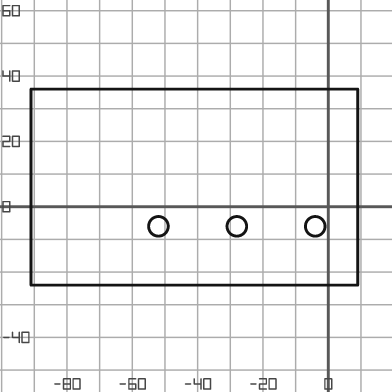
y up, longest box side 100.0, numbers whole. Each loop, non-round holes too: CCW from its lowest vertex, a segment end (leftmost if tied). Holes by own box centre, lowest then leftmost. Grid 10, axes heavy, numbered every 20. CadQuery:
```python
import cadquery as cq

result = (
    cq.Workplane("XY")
    .moveTo(-91.0, -24.0)
    .lineTo(9.0, -24.0)
    .lineTo(9.0, 36.0)
    .lineTo(-91.0, 36.0)
    .close()
    .moveTo(-52.0, -6.0)
    .circle(3.0)
    .moveTo(-28.0, -6.0)
    .circle(3.0)
    .moveTo(-4.0, -6.0)
    .circle(3.0)
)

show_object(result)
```